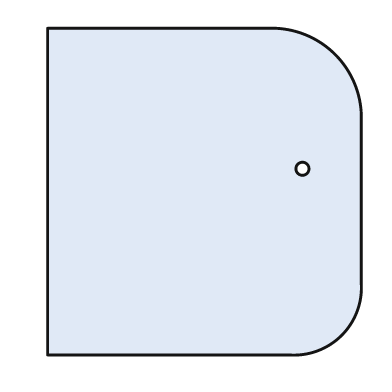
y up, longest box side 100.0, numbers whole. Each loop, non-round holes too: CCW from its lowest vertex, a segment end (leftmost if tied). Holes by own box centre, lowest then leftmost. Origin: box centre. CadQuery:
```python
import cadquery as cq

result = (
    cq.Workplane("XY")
    .moveTo(-48.0, -50.0)
    .lineTo(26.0, -50.0)
    .threePointArc((42.0, -44.0), (48.0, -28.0))
    .lineTo(48.0, 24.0)
    .threePointArc((40.0, 42.0), (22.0, 50.0))
    .lineTo(-48.0, 50.0)
    .close()
    .moveTo(30.0, 7.0)
    .circle(2.0)
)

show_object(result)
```